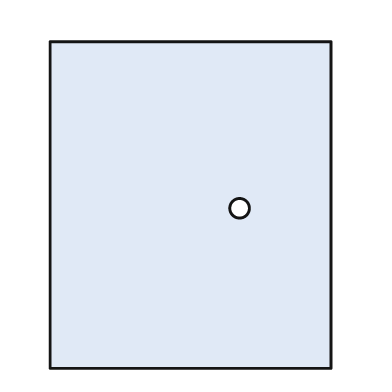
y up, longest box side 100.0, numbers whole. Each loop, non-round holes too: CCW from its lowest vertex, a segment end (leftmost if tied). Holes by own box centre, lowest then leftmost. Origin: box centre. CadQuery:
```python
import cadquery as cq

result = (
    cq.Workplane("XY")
    .moveTo(-43.0, -50.0)
    .lineTo(43.0, -50.0)
    .lineTo(43.0, 50.0)
    .lineTo(-43.0, 50.0)
    .close()
    .moveTo(15.0, -1.0)
    .circle(3.0)
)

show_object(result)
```